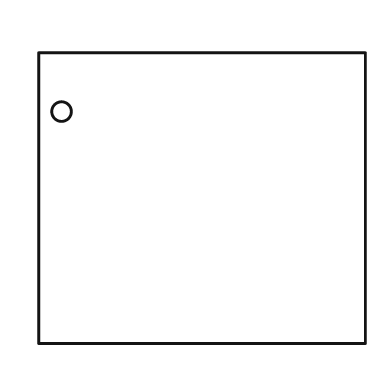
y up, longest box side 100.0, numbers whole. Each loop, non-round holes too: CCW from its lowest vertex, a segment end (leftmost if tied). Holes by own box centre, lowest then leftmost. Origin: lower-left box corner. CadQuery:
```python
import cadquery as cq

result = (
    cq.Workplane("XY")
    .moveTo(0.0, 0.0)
    .lineTo(100.0, 0.0)
    .lineTo(100.0, 89.0)
    .lineTo(0.0, 89.0)
    .close()
    .moveTo(7.0, 71.0)
    .circle(3.0)
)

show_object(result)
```